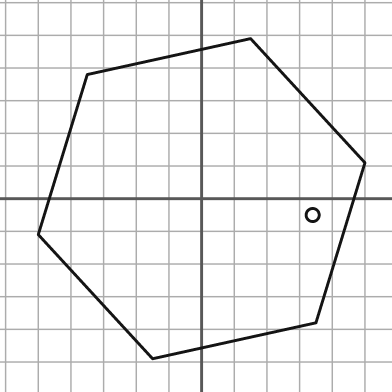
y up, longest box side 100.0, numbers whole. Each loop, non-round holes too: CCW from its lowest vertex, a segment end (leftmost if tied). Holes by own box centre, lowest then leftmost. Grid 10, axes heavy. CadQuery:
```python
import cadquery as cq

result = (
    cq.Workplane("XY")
    .moveTo(-15.0, -49.0)
    .lineTo(35.0, -38.0)
    .lineTo(50.0, 11.0)
    .lineTo(15.0, 49.0)
    .lineTo(-35.0, 38.0)
    .lineTo(-50.0, -11.0)
    .close()
    .moveTo(34.0, -5.0)
    .circle(2.0)
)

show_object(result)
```